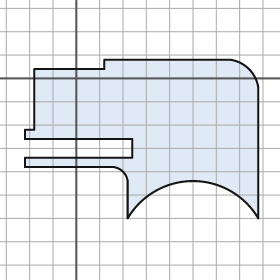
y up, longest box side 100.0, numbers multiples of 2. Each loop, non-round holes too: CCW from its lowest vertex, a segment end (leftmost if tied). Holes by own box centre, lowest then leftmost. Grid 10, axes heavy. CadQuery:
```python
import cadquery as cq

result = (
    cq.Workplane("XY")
    .moveTo(22.0, -60.0)
    .threePointArc((50.0, -44.0), (78.0, -60.0))
    .lineTo(78.0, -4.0)
    .threePointArc((74.0, 4.0), (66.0, 8.0))
    .lineTo(12.0, 8.0)
    .lineTo(12.0, 4.0)
    .lineTo(-18.0, 4.0)
    .lineTo(-18.0, -22.0)
    .lineTo(-22.0, -22.0)
    .lineTo(-22.0, -26.0)
    .lineTo(24.0, -26.0)
    .lineTo(24.0, -34.0)
    .lineTo(-22.0, -34.0)
    .lineTo(-22.0, -38.0)
    .lineTo(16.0, -38.0)
    .threePointArc((20.0, -40.0), (22.0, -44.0))
    .close()
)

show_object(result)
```